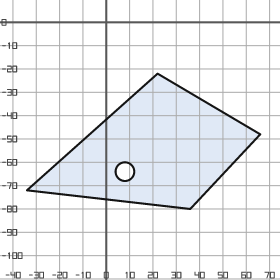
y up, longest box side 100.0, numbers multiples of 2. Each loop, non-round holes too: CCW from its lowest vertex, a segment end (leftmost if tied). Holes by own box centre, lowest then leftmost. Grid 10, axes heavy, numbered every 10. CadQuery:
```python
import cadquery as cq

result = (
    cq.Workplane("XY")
    .moveTo(36.0, -80.0)
    .lineTo(66.0, -48.0)
    .lineTo(22.0, -22.0)
    .lineTo(-34.0, -72.0)
    .close()
    .moveTo(8.0, -64.0)
    .circle(4.0)
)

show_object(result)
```